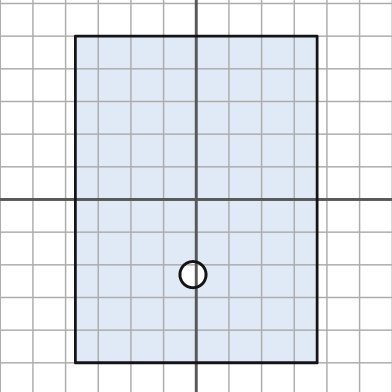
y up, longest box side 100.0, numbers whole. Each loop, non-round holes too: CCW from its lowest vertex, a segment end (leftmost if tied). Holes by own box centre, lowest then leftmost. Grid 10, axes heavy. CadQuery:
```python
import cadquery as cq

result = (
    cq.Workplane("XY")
    .moveTo(-37.0, -50.0)
    .lineTo(37.0, -50.0)
    .lineTo(37.0, 50.0)
    .lineTo(-37.0, 50.0)
    .close()
    .moveTo(-1.0, -23.0)
    .circle(4.0)
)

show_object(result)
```